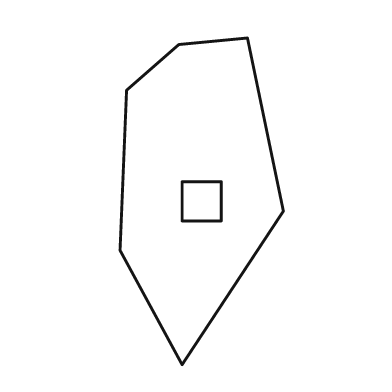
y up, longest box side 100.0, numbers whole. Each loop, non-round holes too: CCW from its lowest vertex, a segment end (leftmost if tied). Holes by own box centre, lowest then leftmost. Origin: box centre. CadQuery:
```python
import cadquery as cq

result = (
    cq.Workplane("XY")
    .moveTo(-6.0, -50.0)
    .lineTo(25.0, -3.0)
    .lineTo(14.0, 50.0)
    .lineTo(-7.0, 48.0)
    .lineTo(-23.0, 34.0)
    .lineTo(-25.0, -15.0)
    .close()
    .moveTo(-6.0, -6.0)
    .lineTo(6.0, -6.0)
    .lineTo(6.0, 6.0)
    .lineTo(-6.0, 6.0)
    .close()
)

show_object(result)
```